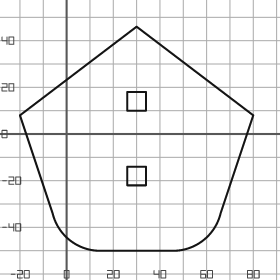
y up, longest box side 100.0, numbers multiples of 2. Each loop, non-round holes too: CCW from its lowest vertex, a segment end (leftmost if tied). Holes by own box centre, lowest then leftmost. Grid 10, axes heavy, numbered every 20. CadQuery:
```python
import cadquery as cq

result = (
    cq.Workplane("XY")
    .moveTo(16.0, -50.0)
    .lineTo(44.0, -50.0)
    .threePointArc((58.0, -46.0), (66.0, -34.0))
    .lineTo(80.0, 8.0)
    .lineTo(30.0, 46.0)
    .lineTo(-20.0, 8.0)
    .lineTo(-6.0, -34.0)
    .threePointArc((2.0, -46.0), (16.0, -50.0))
    .close()
    .moveTo(26.0, -22.0)
    .lineTo(34.0, -22.0)
    .lineTo(34.0, -14.0)
    .lineTo(26.0, -14.0)
    .close()
    .moveTo(26.0, 10.0)
    .lineTo(34.0, 10.0)
    .lineTo(34.0, 18.0)
    .lineTo(26.0, 18.0)
    .close()
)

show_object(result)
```